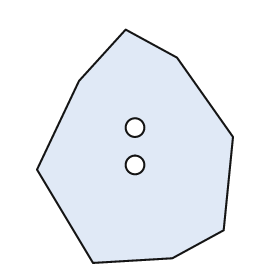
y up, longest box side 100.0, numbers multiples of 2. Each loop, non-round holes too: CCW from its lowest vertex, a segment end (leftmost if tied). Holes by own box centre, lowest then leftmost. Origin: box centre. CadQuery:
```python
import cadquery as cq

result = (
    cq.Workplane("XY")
    .moveTo(-18.0, -50.0)
    .lineTo(16.0, -48.0)
    .lineTo(38.0, -36.0)
    .lineTo(42.0, 4.0)
    .lineTo(18.0, 38.0)
    .lineTo(-4.0, 50.0)
    .lineTo(-24.0, 28.0)
    .lineTo(-42.0, -10.0)
    .close()
    .moveTo(0.0, -8.0)
    .circle(4.0)
    .moveTo(0.0, 8.0)
    .circle(4.0)
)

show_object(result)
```